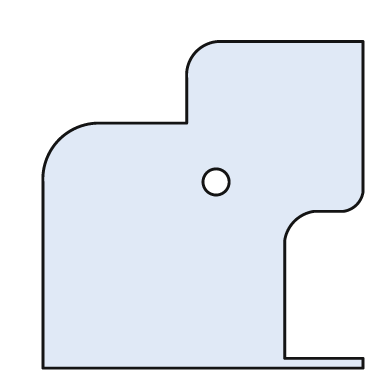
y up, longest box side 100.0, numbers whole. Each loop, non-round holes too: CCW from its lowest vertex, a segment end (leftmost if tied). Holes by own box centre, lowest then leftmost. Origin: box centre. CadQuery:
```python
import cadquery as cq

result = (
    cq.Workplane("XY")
    .moveTo(-49.0, -50.0)
    .lineTo(49.0, -50.0)
    .lineTo(49.0, -47.0)
    .lineTo(25.0, -47.0)
    .lineTo(25.0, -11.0)
    .threePointArc((28.0, -5.0), (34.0, -2.0))
    .lineTo(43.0, -2.0)
    .threePointArc((47.0, 0.0), (49.0, 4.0))
    .lineTo(49.0, 50.0)
    .lineTo(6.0, 50.0)
    .threePointArc((-2.0, 47.0), (-5.0, 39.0))
    .lineTo(-5.0, 25.0)
    .lineTo(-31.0, 25.0)
    .threePointArc((-44.0, 20.0), (-49.0, 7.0))
    .close()
    .moveTo(4.0, 7.0)
    .circle(4.0)
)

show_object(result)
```